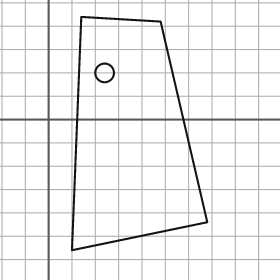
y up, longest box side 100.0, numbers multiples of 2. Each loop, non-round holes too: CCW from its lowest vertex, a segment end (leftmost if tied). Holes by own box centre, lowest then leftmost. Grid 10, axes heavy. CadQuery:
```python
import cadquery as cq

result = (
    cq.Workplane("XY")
    .moveTo(10.0, -56.0)
    .lineTo(68.0, -44.0)
    .lineTo(48.0, 42.0)
    .lineTo(14.0, 44.0)
    .close()
    .moveTo(24.0, 20.0)
    .circle(4.0)
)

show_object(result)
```